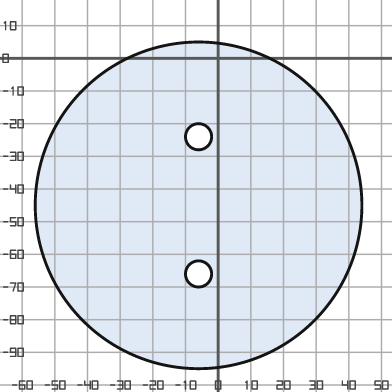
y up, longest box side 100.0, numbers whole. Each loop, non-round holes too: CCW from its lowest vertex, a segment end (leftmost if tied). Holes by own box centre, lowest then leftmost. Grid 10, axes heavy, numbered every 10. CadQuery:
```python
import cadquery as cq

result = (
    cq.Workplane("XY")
    .moveTo(-6.0, -45.0)
    .circle(50.0)
    .moveTo(-6.0, -66.0)
    .circle(4.0)
    .moveTo(-6.0, -24.0)
    .circle(4.0)
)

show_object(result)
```